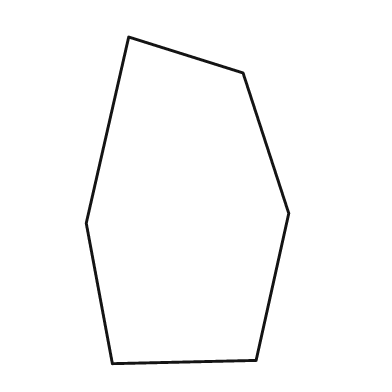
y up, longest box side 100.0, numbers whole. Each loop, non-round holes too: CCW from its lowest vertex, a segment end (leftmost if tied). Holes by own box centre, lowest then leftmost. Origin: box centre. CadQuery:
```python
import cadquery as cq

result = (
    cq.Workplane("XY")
    .moveTo(-23.0, -50.0)
    .lineTo(21.0, -49.0)
    .lineTo(31.0, -4.0)
    .lineTo(17.0, 39.0)
    .lineTo(-18.0, 50.0)
    .lineTo(-31.0, -7.0)
    .close()
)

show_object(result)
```